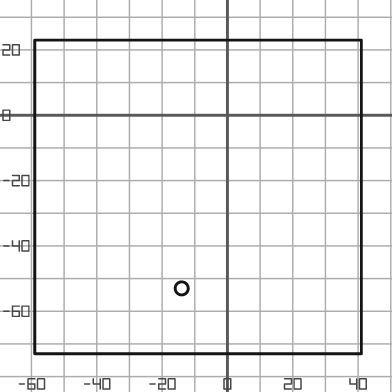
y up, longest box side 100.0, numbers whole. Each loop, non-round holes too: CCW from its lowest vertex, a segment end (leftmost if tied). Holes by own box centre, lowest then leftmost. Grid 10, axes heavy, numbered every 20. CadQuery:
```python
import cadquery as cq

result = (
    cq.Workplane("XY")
    .moveTo(-59.0, -73.0)
    .lineTo(41.0, -73.0)
    .lineTo(41.0, 23.0)
    .lineTo(-59.0, 23.0)
    .close()
    .moveTo(-14.0, -53.0)
    .circle(2.0)
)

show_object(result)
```